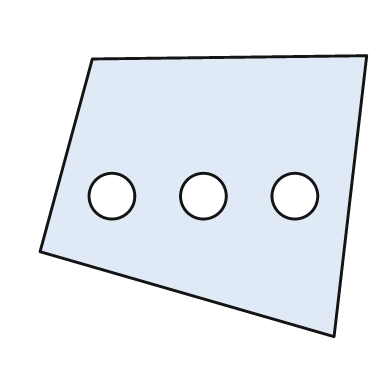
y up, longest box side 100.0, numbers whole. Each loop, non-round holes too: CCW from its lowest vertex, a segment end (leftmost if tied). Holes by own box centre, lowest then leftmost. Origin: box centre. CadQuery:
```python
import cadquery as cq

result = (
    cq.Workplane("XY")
    .moveTo(40.0, -43.0)
    .lineTo(50.0, 43.0)
    .lineTo(-34.0, 42.0)
    .lineTo(-50.0, -17.0)
    .close()
    .moveTo(-28.0, 0.0)
    .circle(7.0)
    .moveTo(0.0, 0.0)
    .circle(7.0)
    .moveTo(28.0, 0.0)
    .circle(7.0)
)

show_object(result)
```